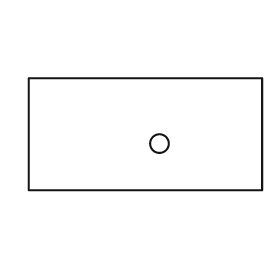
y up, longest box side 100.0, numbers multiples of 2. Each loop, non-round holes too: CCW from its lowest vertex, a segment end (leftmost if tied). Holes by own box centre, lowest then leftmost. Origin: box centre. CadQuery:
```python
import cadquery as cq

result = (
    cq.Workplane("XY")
    .moveTo(-50.0, -24.0)
    .lineTo(50.0, -24.0)
    .lineTo(50.0, 24.0)
    .lineTo(-50.0, 24.0)
    .close()
    .moveTo(6.0, -4.0)
    .circle(4.0)
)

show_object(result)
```